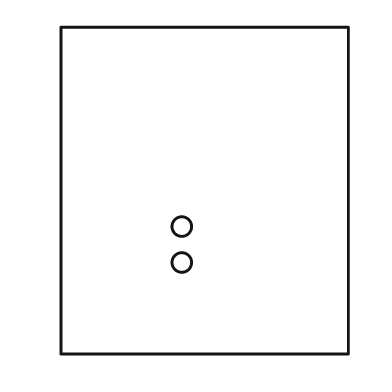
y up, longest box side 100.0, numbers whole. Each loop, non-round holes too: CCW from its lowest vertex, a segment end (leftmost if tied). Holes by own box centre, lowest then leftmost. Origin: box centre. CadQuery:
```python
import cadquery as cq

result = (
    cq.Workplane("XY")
    .moveTo(-44.0, -50.0)
    .lineTo(44.0, -50.0)
    .lineTo(44.0, 50.0)
    .lineTo(-44.0, 50.0)
    .close()
    .moveTo(-7.0, -22.0)
    .circle(3.0)
    .moveTo(-7.0, -11.0)
    .circle(3.0)
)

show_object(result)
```